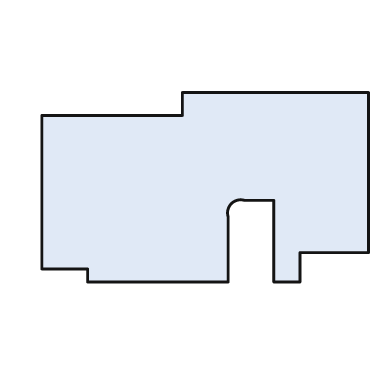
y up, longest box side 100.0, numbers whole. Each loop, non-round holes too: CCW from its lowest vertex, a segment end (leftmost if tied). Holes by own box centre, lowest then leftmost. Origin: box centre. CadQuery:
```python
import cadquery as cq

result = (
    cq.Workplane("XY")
    .moveTo(-36.0, -29.0)
    .lineTo(7.0, -29.0)
    .lineTo(7.0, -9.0)
    .threePointArc((8.0, -5.0), (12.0, -4.0))
    .lineTo(21.0, -4.0)
    .lineTo(21.0, -29.0)
    .lineTo(29.0, -29.0)
    .lineTo(29.0, -20.0)
    .lineTo(50.0, -20.0)
    .lineTo(50.0, 29.0)
    .lineTo(-7.0, 29.0)
    .lineTo(-7.0, 22.0)
    .lineTo(-50.0, 22.0)
    .lineTo(-50.0, -25.0)
    .lineTo(-36.0, -25.0)
    .close()
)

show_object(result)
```